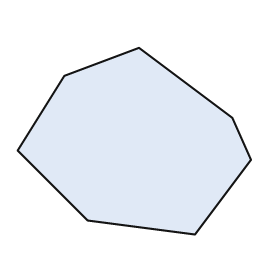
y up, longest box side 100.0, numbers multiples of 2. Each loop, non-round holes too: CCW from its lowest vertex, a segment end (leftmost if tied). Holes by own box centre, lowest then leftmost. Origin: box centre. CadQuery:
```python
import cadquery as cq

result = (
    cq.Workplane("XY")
    .moveTo(26.0, -40.0)
    .lineTo(50.0, -8.0)
    .lineTo(42.0, 10.0)
    .lineTo(2.0, 40.0)
    .lineTo(-30.0, 28.0)
    .lineTo(-50.0, -4.0)
    .lineTo(-20.0, -34.0)
    .close()
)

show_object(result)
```